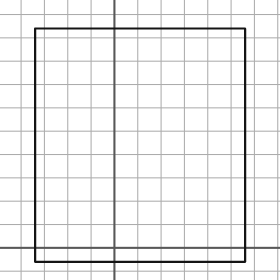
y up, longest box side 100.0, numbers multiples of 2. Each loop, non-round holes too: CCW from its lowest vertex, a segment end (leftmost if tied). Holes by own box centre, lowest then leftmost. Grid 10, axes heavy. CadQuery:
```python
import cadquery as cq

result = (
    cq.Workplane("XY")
    .moveTo(-34.0, -6.0)
    .lineTo(56.0, -6.0)
    .lineTo(56.0, 94.0)
    .lineTo(-34.0, 94.0)
    .close()
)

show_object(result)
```